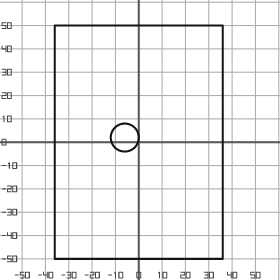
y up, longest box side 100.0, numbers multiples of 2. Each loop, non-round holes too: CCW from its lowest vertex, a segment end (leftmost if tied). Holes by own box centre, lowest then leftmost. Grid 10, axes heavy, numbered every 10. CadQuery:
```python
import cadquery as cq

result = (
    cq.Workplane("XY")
    .moveTo(-36.0, -50.0)
    .lineTo(36.0, -50.0)
    .lineTo(36.0, 50.0)
    .lineTo(-36.0, 50.0)
    .close()
    .moveTo(-6.0, 2.0)
    .circle(6.0)
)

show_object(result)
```